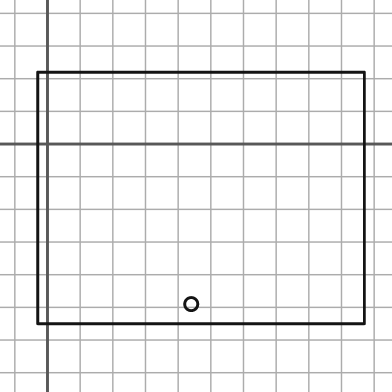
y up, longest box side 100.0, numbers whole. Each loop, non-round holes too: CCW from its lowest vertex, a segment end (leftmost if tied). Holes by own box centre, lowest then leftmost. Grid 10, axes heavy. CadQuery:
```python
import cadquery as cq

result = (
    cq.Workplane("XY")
    .moveTo(-3.0, -55.0)
    .lineTo(97.0, -55.0)
    .lineTo(97.0, 22.0)
    .lineTo(-3.0, 22.0)
    .close()
    .moveTo(44.0, -49.0)
    .circle(2.0)
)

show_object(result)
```